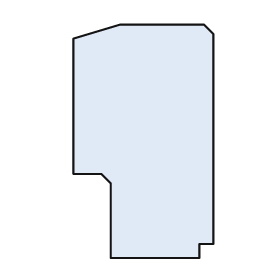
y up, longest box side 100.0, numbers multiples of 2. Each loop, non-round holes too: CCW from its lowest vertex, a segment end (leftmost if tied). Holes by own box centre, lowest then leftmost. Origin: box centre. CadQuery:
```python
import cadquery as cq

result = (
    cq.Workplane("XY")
    .moveTo(-14.0, -50.0)
    .lineTo(24.0, -50.0)
    .lineTo(24.0, -44.0)
    .lineTo(30.0, -44.0)
    .lineTo(30.0, 46.0)
    .lineTo(26.0, 50.0)
    .lineTo(-10.0, 50.0)
    .lineTo(-30.0, 44.0)
    .lineTo(-30.0, -14.0)
    .lineTo(-18.0, -14.0)
    .lineTo(-14.0, -18.0)
    .close()
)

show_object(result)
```